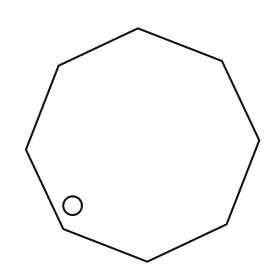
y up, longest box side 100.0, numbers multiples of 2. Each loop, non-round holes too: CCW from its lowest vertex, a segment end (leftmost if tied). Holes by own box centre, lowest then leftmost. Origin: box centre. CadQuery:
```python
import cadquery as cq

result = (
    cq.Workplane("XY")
    .moveTo(2.0, -50.0)
    .lineTo(36.0, -34.0)
    .lineTo(50.0, 2.0)
    .lineTo(34.0, 36.0)
    .lineTo(-2.0, 50.0)
    .lineTo(-36.0, 34.0)
    .lineTo(-50.0, -2.0)
    .lineTo(-34.0, -36.0)
    .close()
    .moveTo(-30.0, -26.0)
    .circle(4.0)
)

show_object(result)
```